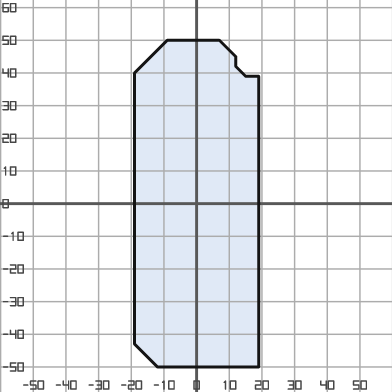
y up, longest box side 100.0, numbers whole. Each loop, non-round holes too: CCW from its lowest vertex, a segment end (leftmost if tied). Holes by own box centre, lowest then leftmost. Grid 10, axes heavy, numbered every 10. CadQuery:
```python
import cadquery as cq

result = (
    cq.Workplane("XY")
    .moveTo(-12.0, -50.0)
    .lineTo(19.0, -50.0)
    .lineTo(19.0, 39.0)
    .lineTo(15.0, 39.0)
    .lineTo(12.0, 42.0)
    .lineTo(12.0, 45.0)
    .lineTo(7.0, 50.0)
    .lineTo(-9.0, 50.0)
    .lineTo(-19.0, 40.0)
    .lineTo(-19.0, -43.0)
    .close()
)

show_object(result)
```